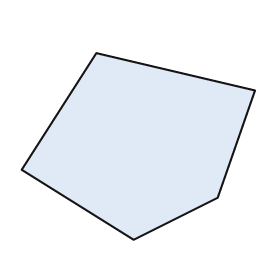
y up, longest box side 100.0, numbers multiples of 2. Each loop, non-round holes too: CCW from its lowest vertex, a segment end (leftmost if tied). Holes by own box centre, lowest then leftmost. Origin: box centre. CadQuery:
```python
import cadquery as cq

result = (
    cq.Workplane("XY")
    .moveTo(-2.0, -40.0)
    .lineTo(34.0, -22.0)
    .lineTo(50.0, 24.0)
    .lineTo(-18.0, 40.0)
    .lineTo(-50.0, -10.0)
    .close()
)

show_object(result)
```